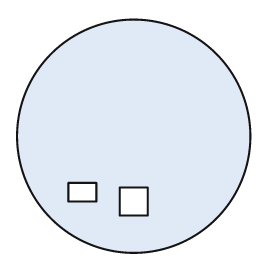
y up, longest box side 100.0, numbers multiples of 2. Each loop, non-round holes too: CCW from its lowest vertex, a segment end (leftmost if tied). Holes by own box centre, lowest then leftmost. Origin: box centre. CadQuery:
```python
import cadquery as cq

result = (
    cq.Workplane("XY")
    .moveTo(0.0, 0.0)
    .circle(50.0)
    .moveTo(-6.0, -34.0)
    .lineTo(6.0, -34.0)
    .lineTo(6.0, -22.0)
    .lineTo(-6.0, -22.0)
    .close()
    .moveTo(-28.0, -28.0)
    .lineTo(-16.0, -28.0)
    .lineTo(-16.0, -20.0)
    .lineTo(-28.0, -20.0)
    .close()
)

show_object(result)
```